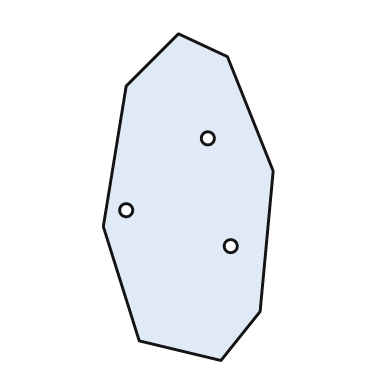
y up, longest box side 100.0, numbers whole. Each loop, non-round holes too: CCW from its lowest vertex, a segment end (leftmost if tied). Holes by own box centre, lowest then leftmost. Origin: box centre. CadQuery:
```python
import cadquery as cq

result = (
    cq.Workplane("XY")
    .moveTo(10.0, -50.0)
    .lineTo(22.0, -35.0)
    .lineTo(26.0, 8.0)
    .lineTo(12.0, 43.0)
    .lineTo(-3.0, 50.0)
    .lineTo(-19.0, 34.0)
    .lineTo(-26.0, -9.0)
    .lineTo(-15.0, -44.0)
    .close()
    .moveTo(13.0, -15.0)
    .circle(2.0)
    .moveTo(-19.0, -4.0)
    .circle(2.0)
    .moveTo(6.0, 18.0)
    .circle(2.0)
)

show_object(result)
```